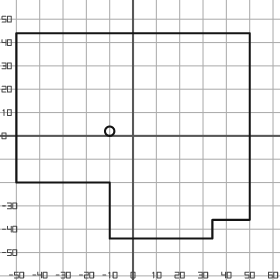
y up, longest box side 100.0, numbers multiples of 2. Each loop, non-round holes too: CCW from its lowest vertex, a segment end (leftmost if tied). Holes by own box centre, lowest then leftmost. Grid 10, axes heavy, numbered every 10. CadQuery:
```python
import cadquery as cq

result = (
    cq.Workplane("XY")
    .moveTo(-10.0, -44.0)
    .lineTo(34.0, -44.0)
    .lineTo(34.0, -36.0)
    .lineTo(50.0, -36.0)
    .lineTo(50.0, 44.0)
    .lineTo(-50.0, 44.0)
    .lineTo(-50.0, -20.0)
    .lineTo(-10.0, -20.0)
    .close()
    .moveTo(-10.0, 2.0)
    .circle(2.0)
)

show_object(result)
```